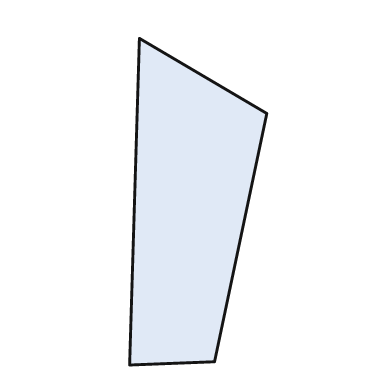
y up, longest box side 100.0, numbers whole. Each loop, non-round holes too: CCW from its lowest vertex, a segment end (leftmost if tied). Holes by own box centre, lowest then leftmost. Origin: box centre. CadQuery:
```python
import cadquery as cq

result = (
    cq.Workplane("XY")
    .moveTo(-21.0, -50.0)
    .lineTo(5.0, -49.0)
    .lineTo(21.0, 27.0)
    .lineTo(-18.0, 50.0)
    .close()
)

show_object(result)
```